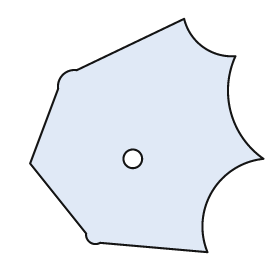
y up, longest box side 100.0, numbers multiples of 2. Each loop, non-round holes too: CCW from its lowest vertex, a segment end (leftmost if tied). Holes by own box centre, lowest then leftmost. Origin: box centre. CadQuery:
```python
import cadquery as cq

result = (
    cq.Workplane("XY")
    .moveTo(26.0, -50.0)
    .threePointArc((28.0, -24.0), (50.0, -10.0))
    .threePointArc((36.0, 10.0), (38.0, 34.0))
    .threePointArc((24.0, 38.0), (16.0, 50.0))
    .lineTo(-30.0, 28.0)
    .threePointArc((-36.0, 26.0), (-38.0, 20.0))
    .lineTo(-50.0, -12.0)
    .lineTo(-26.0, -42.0)
    .threePointArc((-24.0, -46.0), (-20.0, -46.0))
    .close()
    .moveTo(-6.0, -10.0)
    .circle(4.0)
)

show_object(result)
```